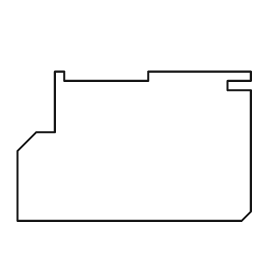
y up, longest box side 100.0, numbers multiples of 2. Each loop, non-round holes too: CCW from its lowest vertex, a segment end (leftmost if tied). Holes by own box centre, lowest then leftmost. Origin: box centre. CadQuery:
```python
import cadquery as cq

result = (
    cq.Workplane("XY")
    .moveTo(-50.0, -32.0)
    .lineTo(46.0, -32.0)
    .lineTo(50.0, -28.0)
    .lineTo(50.0, 24.0)
    .lineTo(40.0, 24.0)
    .lineTo(40.0, 28.0)
    .lineTo(50.0, 28.0)
    .lineTo(50.0, 32.0)
    .lineTo(6.0, 32.0)
    .lineTo(6.0, 28.0)
    .lineTo(-30.0, 28.0)
    .lineTo(-30.0, 32.0)
    .lineTo(-34.0, 32.0)
    .lineTo(-34.0, 6.0)
    .lineTo(-42.0, 6.0)
    .lineTo(-50.0, -2.0)
    .close()
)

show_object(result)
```